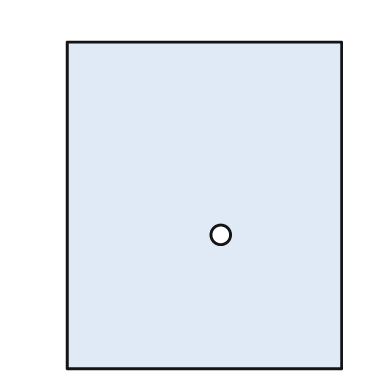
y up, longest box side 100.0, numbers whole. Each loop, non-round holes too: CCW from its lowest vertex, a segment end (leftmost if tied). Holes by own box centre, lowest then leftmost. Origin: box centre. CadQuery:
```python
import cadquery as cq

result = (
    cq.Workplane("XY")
    .moveTo(-42.0, -50.0)
    .lineTo(42.0, -50.0)
    .lineTo(42.0, 50.0)
    .lineTo(-42.0, 50.0)
    .close()
    .moveTo(5.0, -9.0)
    .circle(3.0)
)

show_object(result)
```